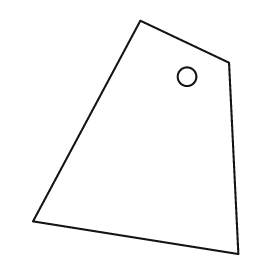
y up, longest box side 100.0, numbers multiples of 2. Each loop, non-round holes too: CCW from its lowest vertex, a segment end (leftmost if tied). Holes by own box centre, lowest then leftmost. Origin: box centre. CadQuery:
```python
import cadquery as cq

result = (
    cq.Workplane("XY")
    .moveTo(44.0, -50.0)
    .lineTo(40.0, 32.0)
    .lineTo(2.0, 50.0)
    .lineTo(-44.0, -36.0)
    .close()
    .moveTo(22.0, 26.0)
    .circle(4.0)
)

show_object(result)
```